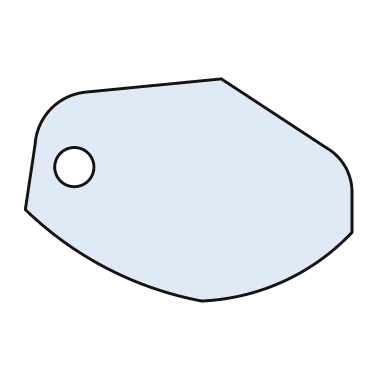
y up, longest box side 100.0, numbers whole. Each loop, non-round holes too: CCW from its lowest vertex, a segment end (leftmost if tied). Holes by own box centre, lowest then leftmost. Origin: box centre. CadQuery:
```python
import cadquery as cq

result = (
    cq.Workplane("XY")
    .moveTo(4.0, -34.0)
    .threePointArc((29.0, -28.0), (50.0, -13.0))
    .lineTo(50.0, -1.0)
    .threePointArc((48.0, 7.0), (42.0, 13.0))
    .lineTo(10.0, 34.0)
    .lineTo(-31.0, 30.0)
    .threePointArc((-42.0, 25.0), (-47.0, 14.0))
    .lineTo(-50.0, -6.0)
    .threePointArc((-25.0, -24.0), (4.0, -34.0))
    .close()
    .moveTo(-35.0, 7.0)
    .circle(6.0)
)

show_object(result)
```